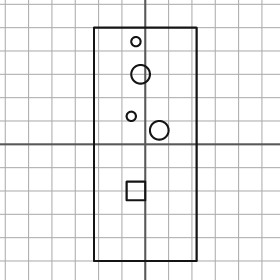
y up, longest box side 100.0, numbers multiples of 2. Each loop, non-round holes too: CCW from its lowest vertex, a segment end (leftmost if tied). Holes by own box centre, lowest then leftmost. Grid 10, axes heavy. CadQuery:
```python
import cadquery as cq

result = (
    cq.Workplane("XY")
    .moveTo(-22.0, -50.0)
    .lineTo(22.0, -50.0)
    .lineTo(22.0, 50.0)
    .lineTo(-22.0, 50.0)
    .close()
    .moveTo(-8.0, -24.0)
    .lineTo(0.0, -24.0)
    .lineTo(0.0, -16.0)
    .lineTo(-8.0, -16.0)
    .close()
    .moveTo(6.0, 6.0)
    .circle(4.0)
    .moveTo(-6.0, 12.0)
    .circle(2.0)
    .moveTo(-2.0, 30.0)
    .circle(4.0)
    .moveTo(-4.0, 44.0)
    .circle(2.0)
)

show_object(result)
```